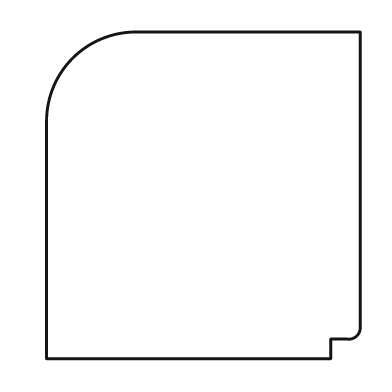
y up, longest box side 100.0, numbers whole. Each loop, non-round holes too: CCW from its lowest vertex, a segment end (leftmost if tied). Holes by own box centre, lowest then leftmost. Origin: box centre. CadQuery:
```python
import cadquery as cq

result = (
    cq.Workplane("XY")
    .moveTo(-48.0, -50.0)
    .lineTo(39.0, -50.0)
    .lineTo(39.0, -44.0)
    .lineTo(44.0, -44.0)
    .threePointArc((47.0, -43.0), (48.0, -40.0))
    .lineTo(48.0, 50.0)
    .lineTo(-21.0, 50.0)
    .threePointArc((-40.0, 42.0), (-48.0, 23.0))
    .close()
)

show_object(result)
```